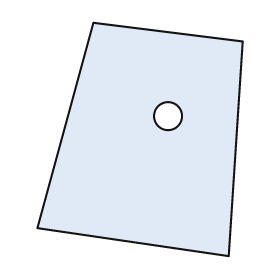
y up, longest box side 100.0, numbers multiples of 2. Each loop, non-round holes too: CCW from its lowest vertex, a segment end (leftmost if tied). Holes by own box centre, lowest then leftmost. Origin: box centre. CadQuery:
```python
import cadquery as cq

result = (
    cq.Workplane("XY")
    .moveTo(38.0, -50.0)
    .lineTo(44.0, 42.0)
    .lineTo(-20.0, 50.0)
    .lineTo(-44.0, -38.0)
    .close()
    .moveTo(12.0, 10.0)
    .circle(6.0)
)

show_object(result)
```